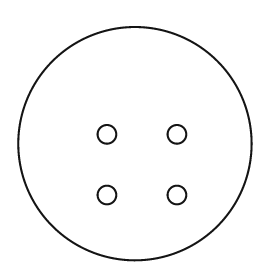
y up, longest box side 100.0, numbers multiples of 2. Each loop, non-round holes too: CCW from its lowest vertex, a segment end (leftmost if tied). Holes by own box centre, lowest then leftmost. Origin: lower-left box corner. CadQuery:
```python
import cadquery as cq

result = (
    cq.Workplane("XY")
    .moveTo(50.0, 50.0)
    .circle(50.0)
    .moveTo(38.0, 28.0)
    .circle(4.0)
    .moveTo(68.0, 28.0)
    .circle(4.0)
    .moveTo(38.0, 54.0)
    .circle(4.0)
    .moveTo(68.0, 54.0)
    .circle(4.0)
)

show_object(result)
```